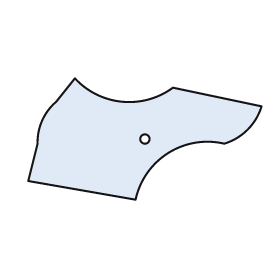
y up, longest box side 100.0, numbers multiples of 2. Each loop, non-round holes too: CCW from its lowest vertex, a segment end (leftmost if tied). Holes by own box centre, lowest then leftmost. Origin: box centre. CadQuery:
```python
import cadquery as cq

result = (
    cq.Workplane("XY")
    .moveTo(-4.0, -26.0)
    .threePointArc((10.0, -6.0), (34.0, -2.0))
    .threePointArc((44.0, 4.0), (50.0, 14.0))
    .lineTo(12.0, 22.0)
    .threePointArc((-10.0, 16.0), (-30.0, 26.0))
    .lineTo(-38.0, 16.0)
    .threePointArc((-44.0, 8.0), (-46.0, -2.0))
    .lineTo(-50.0, -18.0)
    .close()
    .moveTo(0.0, 0.0)
    .circle(2.0)
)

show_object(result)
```